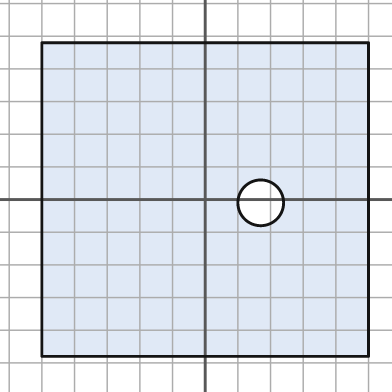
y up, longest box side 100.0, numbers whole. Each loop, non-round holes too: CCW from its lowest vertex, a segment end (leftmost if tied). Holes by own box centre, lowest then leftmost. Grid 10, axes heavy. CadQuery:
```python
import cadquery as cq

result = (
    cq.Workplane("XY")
    .moveTo(-50.0, -48.0)
    .lineTo(50.0, -48.0)
    .lineTo(50.0, 48.0)
    .lineTo(-50.0, 48.0)
    .close()
    .moveTo(17.0, -1.0)
    .circle(7.0)
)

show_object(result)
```